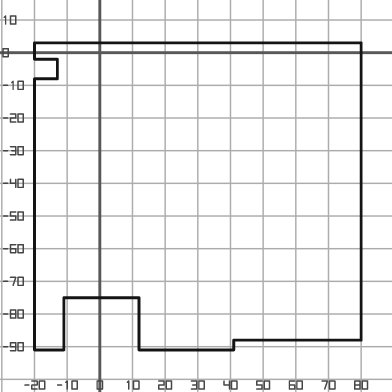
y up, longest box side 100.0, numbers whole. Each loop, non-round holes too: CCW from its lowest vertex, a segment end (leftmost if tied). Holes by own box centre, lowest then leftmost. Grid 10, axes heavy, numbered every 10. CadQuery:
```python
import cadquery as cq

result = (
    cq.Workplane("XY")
    .moveTo(-20.0, -91.0)
    .lineTo(-11.0, -91.0)
    .lineTo(-11.0, -75.0)
    .lineTo(12.0, -75.0)
    .lineTo(12.0, -91.0)
    .lineTo(41.0, -91.0)
    .lineTo(41.0, -88.0)
    .lineTo(80.0, -88.0)
    .lineTo(80.0, 3.0)
    .lineTo(-20.0, 3.0)
    .lineTo(-20.0, -2.0)
    .lineTo(-13.0, -2.0)
    .lineTo(-13.0, -8.0)
    .lineTo(-20.0, -8.0)
    .close()
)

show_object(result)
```